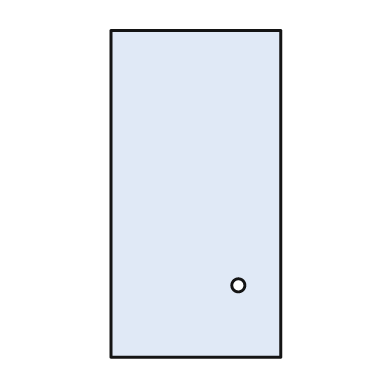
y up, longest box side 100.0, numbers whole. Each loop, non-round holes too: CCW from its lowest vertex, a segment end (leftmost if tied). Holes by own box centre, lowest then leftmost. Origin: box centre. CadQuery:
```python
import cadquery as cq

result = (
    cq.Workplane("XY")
    .moveTo(-26.0, -50.0)
    .lineTo(26.0, -50.0)
    .lineTo(26.0, 50.0)
    .lineTo(-26.0, 50.0)
    .close()
    .moveTo(13.0, -28.0)
    .circle(2.0)
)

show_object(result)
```